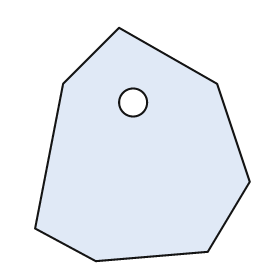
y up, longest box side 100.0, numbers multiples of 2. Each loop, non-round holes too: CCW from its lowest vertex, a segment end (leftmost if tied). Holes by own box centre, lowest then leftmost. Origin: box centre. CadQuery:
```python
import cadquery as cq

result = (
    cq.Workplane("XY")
    .moveTo(-20.0, -50.0)
    .lineTo(28.0, -46.0)
    .lineTo(46.0, -16.0)
    .lineTo(32.0, 26.0)
    .lineTo(-10.0, 50.0)
    .lineTo(-34.0, 26.0)
    .lineTo(-46.0, -36.0)
    .close()
    .moveTo(-4.0, 18.0)
    .circle(6.0)
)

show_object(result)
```